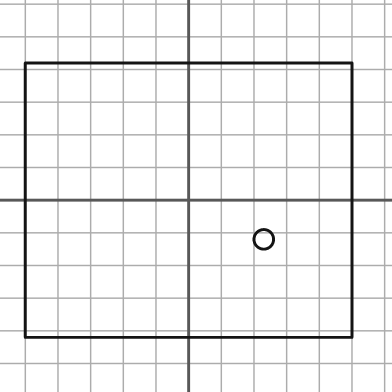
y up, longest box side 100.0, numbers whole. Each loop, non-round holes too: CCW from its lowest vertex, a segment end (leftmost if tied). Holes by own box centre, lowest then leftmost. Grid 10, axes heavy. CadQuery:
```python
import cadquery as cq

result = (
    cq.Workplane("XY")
    .moveTo(-50.0, -42.0)
    .lineTo(50.0, -42.0)
    .lineTo(50.0, 42.0)
    .lineTo(-50.0, 42.0)
    .close()
    .moveTo(23.0, -12.0)
    .circle(3.0)
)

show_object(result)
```